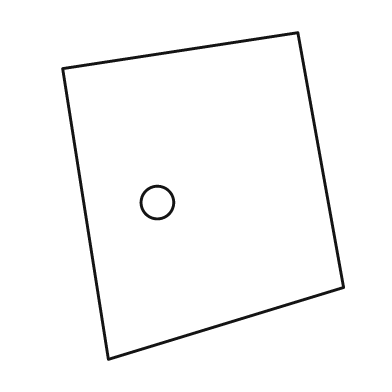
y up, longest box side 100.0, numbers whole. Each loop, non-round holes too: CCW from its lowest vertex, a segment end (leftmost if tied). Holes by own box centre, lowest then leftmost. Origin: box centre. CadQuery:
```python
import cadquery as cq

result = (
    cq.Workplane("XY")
    .moveTo(-29.0, -50.0)
    .lineTo(43.0, -28.0)
    .lineTo(29.0, 50.0)
    .lineTo(-43.0, 39.0)
    .close()
    .moveTo(-14.0, -2.0)
    .circle(5.0)
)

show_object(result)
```